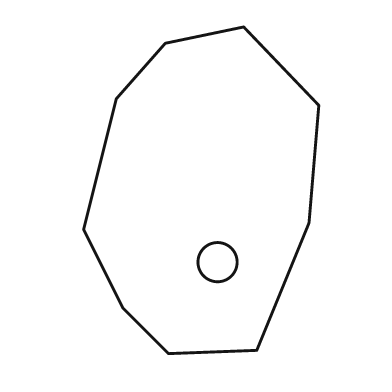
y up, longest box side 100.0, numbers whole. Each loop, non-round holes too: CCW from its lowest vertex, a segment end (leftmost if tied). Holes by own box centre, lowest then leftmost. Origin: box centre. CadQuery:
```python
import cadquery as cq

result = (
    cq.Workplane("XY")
    .moveTo(-10.0, -50.0)
    .lineTo(17.0, -49.0)
    .lineTo(33.0, -10.0)
    .lineTo(36.0, 26.0)
    .lineTo(13.0, 50.0)
    .lineTo(-11.0, 45.0)
    .lineTo(-26.0, 28.0)
    .lineTo(-36.0, -12.0)
    .lineTo(-24.0, -36.0)
    .close()
    .moveTo(5.0, -22.0)
    .circle(6.0)
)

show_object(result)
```